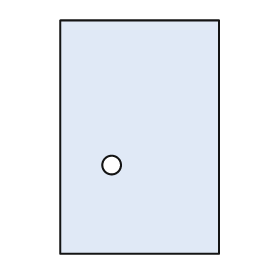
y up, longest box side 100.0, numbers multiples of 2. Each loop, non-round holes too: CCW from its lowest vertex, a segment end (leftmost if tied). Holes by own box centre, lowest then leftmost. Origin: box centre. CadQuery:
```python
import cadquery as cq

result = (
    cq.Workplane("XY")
    .moveTo(-34.0, -50.0)
    .lineTo(34.0, -50.0)
    .lineTo(34.0, 50.0)
    .lineTo(-34.0, 50.0)
    .close()
    .moveTo(-12.0, -12.0)
    .circle(4.0)
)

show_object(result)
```